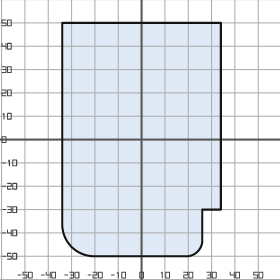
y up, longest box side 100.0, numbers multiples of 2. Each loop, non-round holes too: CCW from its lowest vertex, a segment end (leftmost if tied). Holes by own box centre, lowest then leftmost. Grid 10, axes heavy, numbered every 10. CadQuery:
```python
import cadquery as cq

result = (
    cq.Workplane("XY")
    .moveTo(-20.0, -50.0)
    .lineTo(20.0, -50.0)
    .threePointArc((24.0, -48.0), (26.0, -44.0))
    .lineTo(26.0, -30.0)
    .lineTo(34.0, -30.0)
    .lineTo(34.0, 50.0)
    .lineTo(-34.0, 50.0)
    .lineTo(-34.0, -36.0)
    .threePointArc((-30.0, -46.0), (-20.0, -50.0))
    .close()
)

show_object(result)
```